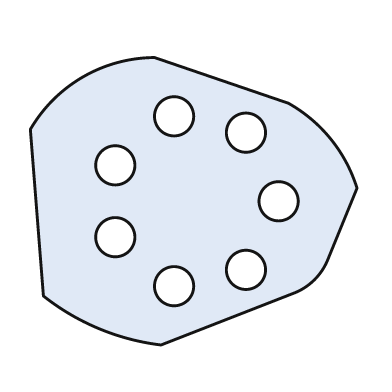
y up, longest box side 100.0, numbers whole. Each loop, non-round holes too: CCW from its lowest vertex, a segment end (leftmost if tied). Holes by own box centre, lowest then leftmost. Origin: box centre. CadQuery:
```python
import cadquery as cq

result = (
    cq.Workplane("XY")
    .moveTo(-10.0, -44.0)
    .lineTo(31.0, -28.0)
    .threePointArc((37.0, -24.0), (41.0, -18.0))
    .lineTo(50.0, 4.0)
    .threePointArc((42.0, 19.0), (29.0, 30.0))
    .lineTo(-12.0, 44.0)
    .threePointArc((-34.0, 38.0), (-50.0, 22.0))
    .lineTo(-46.0, -29.0)
    .threePointArc((-29.0, -39.0), (-10.0, -44.0))
    .close()
    .moveTo(-6.0, -26.0)
    .circle(6.0)
    .moveTo(16.0, -21.0)
    .circle(6.0)
    .moveTo(-24.0, -11.0)
    .circle(6.0)
    .moveTo(26.0, 0.0)
    .circle(6.0)
    .moveTo(-24.0, 11.0)
    .circle(6.0)
    .moveTo(16.0, 21.0)
    .circle(6.0)
    .moveTo(-6.0, 26.0)
    .circle(6.0)
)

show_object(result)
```